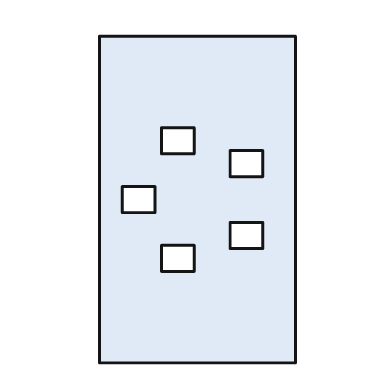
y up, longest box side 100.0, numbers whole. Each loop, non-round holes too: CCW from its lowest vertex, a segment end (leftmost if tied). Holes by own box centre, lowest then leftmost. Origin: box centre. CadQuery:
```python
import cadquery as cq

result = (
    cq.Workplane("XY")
    .moveTo(-30.0, -50.0)
    .lineTo(30.0, -50.0)
    .lineTo(30.0, 50.0)
    .lineTo(-30.0, 50.0)
    .close()
    .moveTo(-11.0, -22.0)
    .lineTo(-1.0, -22.0)
    .lineTo(-1.0, -14.0)
    .lineTo(-11.0, -14.0)
    .close()
    .moveTo(10.0, -15.0)
    .lineTo(20.0, -15.0)
    .lineTo(20.0, -7.0)
    .lineTo(10.0, -7.0)
    .close()
    .moveTo(-23.0, -4.0)
    .lineTo(-13.0, -4.0)
    .lineTo(-13.0, 4.0)
    .lineTo(-23.0, 4.0)
    .close()
    .moveTo(10.0, 7.0)
    .lineTo(20.0, 7.0)
    .lineTo(20.0, 15.0)
    .lineTo(10.0, 15.0)
    .close()
    .moveTo(-11.0, 14.0)
    .lineTo(-1.0, 14.0)
    .lineTo(-1.0, 22.0)
    .lineTo(-11.0, 22.0)
    .close()
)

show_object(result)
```